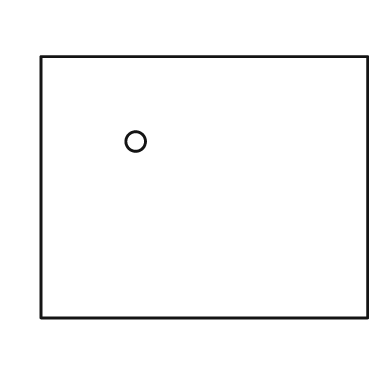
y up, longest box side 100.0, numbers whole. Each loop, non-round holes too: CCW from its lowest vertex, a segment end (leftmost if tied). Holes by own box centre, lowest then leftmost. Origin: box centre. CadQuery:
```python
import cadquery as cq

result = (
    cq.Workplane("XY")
    .moveTo(-50.0, -40.0)
    .lineTo(50.0, -40.0)
    .lineTo(50.0, 40.0)
    .lineTo(-50.0, 40.0)
    .close()
    .moveTo(-21.0, 14.0)
    .circle(3.0)
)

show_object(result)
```